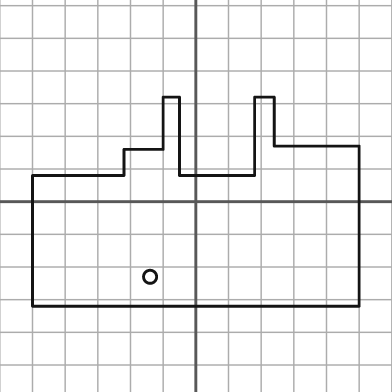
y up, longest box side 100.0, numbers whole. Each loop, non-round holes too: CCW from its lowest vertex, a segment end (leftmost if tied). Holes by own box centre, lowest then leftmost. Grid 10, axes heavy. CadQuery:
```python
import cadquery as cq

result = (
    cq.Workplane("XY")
    .moveTo(-50.0, -32.0)
    .lineTo(50.0, -32.0)
    .lineTo(50.0, 17.0)
    .lineTo(24.0, 17.0)
    .lineTo(24.0, 32.0)
    .lineTo(18.0, 32.0)
    .lineTo(18.0, 8.0)
    .lineTo(-5.0, 8.0)
    .lineTo(-5.0, 32.0)
    .lineTo(-10.0, 32.0)
    .lineTo(-10.0, 16.0)
    .lineTo(-22.0, 16.0)
    .lineTo(-22.0, 8.0)
    .lineTo(-50.0, 8.0)
    .close()
    .moveTo(-14.0, -23.0)
    .circle(2.0)
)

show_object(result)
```